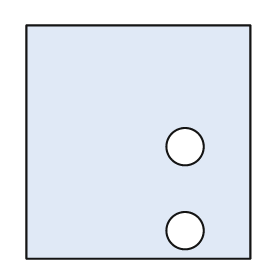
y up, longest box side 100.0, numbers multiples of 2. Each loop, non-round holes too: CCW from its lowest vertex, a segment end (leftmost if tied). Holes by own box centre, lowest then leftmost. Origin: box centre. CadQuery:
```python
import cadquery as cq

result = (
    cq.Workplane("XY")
    .moveTo(-48.0, -50.0)
    .lineTo(48.0, -50.0)
    .lineTo(48.0, 50.0)
    .lineTo(-48.0, 50.0)
    .close()
    .moveTo(20.0, -38.0)
    .circle(8.0)
    .moveTo(20.0, -2.0)
    .circle(8.0)
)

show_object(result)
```